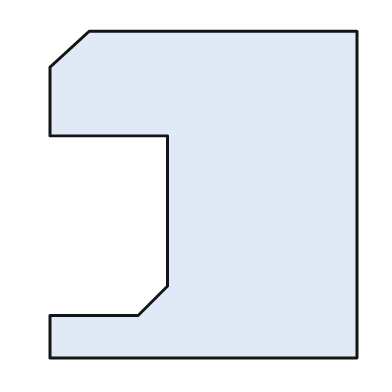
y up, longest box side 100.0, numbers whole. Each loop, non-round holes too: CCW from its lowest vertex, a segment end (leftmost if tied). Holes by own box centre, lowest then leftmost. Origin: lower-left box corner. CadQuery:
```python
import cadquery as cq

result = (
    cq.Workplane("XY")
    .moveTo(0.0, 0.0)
    .lineTo(94.0, 0.0)
    .lineTo(94.0, 100.0)
    .lineTo(12.0, 100.0)
    .lineTo(0.0, 89.0)
    .lineTo(0.0, 68.0)
    .lineTo(36.0, 68.0)
    .lineTo(36.0, 22.0)
    .lineTo(27.0, 13.0)
    .lineTo(0.0, 13.0)
    .close()
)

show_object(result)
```